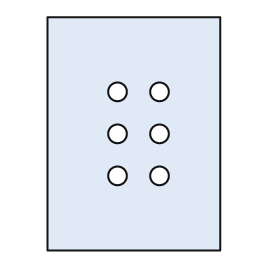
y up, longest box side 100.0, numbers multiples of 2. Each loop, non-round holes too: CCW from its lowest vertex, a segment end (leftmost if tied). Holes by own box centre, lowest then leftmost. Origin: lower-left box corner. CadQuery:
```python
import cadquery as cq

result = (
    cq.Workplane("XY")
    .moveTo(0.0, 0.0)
    .lineTo(74.0, 0.0)
    .lineTo(74.0, 100.0)
    .lineTo(0.0, 100.0)
    .close()
    .moveTo(30.0, 32.0)
    .circle(4.0)
    .moveTo(48.0, 32.0)
    .circle(4.0)
    .moveTo(30.0, 50.0)
    .circle(4.0)
    .moveTo(48.0, 50.0)
    .circle(4.0)
    .moveTo(30.0, 68.0)
    .circle(4.0)
    .moveTo(48.0, 68.0)
    .circle(4.0)
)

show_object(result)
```